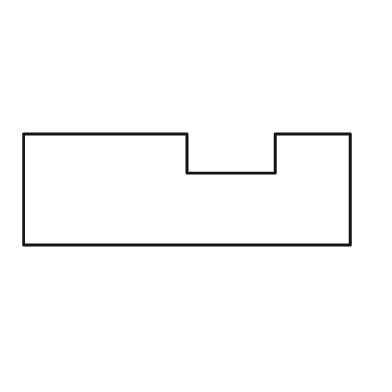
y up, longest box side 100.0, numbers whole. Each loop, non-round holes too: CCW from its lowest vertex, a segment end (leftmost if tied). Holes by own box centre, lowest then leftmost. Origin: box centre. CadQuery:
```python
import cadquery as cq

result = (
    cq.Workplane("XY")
    .moveTo(-50.0, -17.0)
    .lineTo(50.0, -17.0)
    .lineTo(50.0, 17.0)
    .lineTo(27.0, 17.0)
    .lineTo(27.0, 5.0)
    .lineTo(0.0, 5.0)
    .lineTo(0.0, 17.0)
    .lineTo(-50.0, 17.0)
    .close()
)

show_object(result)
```